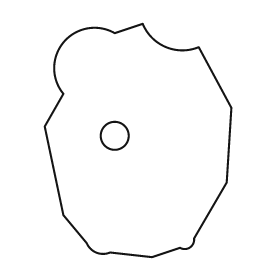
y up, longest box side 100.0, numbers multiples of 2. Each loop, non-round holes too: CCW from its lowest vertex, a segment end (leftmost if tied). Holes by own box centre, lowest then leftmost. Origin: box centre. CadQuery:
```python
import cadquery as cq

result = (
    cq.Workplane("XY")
    .moveTo(6.0, -50.0)
    .lineTo(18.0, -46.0)
    .threePointArc((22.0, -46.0), (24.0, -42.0))
    .lineTo(38.0, -18.0)
    .lineTo(40.0, 14.0)
    .lineTo(26.0, 40.0)
    .threePointArc((12.0, 40.0), (2.0, 50.0))
    .lineTo(-10.0, 46.0)
    .threePointArc((-32.0, 42.0), (-32.0, 20.0))
    .lineTo(-40.0, 6.0)
    .lineTo(-32.0, -32.0)
    .lineTo(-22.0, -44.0)
    .threePointArc((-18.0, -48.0), (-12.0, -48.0))
    .close()
    .moveTo(-10.0, 2.0)
    .circle(6.0)
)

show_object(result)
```